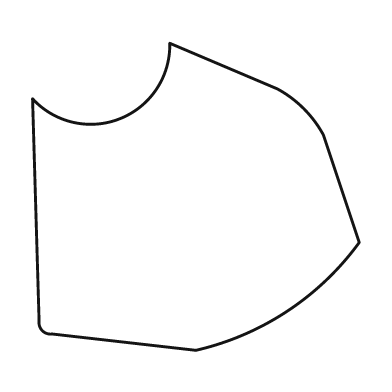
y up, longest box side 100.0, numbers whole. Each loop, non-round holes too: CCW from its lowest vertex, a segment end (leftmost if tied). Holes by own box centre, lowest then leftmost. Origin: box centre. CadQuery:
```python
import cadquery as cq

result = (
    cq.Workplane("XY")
    .moveTo(0.0, -47.0)
    .threePointArc((28.0, -35.0), (50.0, -14.0))
    .lineTo(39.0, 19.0)
    .threePointArc((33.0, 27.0), (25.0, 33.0))
    .lineTo(-8.0, 47.0)
    .threePointArc((-23.0, 24.0), (-50.0, 30.0))
    .lineTo(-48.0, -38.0)
    .threePointArc((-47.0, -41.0), (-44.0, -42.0))
    .close()
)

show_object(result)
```